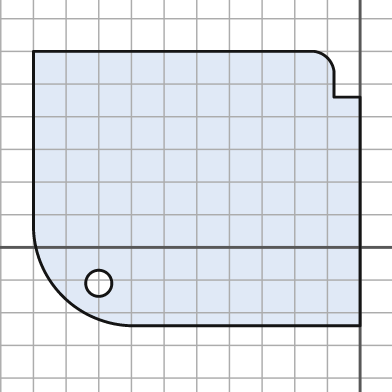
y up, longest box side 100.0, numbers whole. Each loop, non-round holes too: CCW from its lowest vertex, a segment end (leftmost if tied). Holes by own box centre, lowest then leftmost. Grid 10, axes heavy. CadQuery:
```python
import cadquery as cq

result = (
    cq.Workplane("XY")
    .moveTo(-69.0, -24.0)
    .lineTo(0.0, -24.0)
    .lineTo(0.0, 46.0)
    .lineTo(-8.0, 46.0)
    .lineTo(-8.0, 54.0)
    .threePointArc((-10.0, 58.0), (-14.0, 60.0))
    .lineTo(-100.0, 60.0)
    .lineTo(-100.0, 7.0)
    .threePointArc((-91.0, -15.0), (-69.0, -24.0))
    .close()
    .moveTo(-80.0, -11.0)
    .circle(4.0)
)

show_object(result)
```